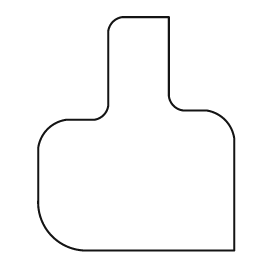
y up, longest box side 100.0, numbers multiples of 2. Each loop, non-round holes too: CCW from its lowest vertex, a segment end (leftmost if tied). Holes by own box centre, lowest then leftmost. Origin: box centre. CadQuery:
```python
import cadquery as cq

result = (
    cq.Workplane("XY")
    .moveTo(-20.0, -50.0)
    .lineTo(42.0, -50.0)
    .lineTo(42.0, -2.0)
    .threePointArc((38.0, 6.0), (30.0, 10.0))
    .lineTo(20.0, 10.0)
    .threePointArc((16.0, 12.0), (14.0, 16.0))
    .lineTo(14.0, 50.0)
    .lineTo(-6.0, 50.0)
    .threePointArc((-10.0, 48.0), (-12.0, 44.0))
    .lineTo(-12.0, 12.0)
    .threePointArc((-14.0, 8.0), (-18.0, 6.0))
    .lineTo(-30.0, 6.0)
    .threePointArc((-38.0, 2.0), (-42.0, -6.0))
    .lineTo(-42.0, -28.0)
    .threePointArc((-36.0, -44.0), (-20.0, -50.0))
    .close()
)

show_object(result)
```